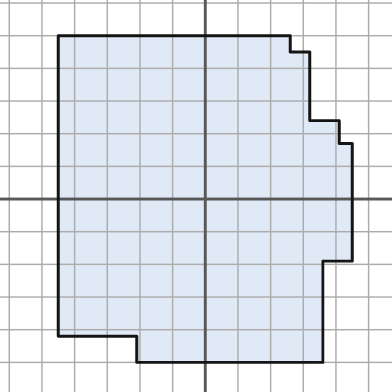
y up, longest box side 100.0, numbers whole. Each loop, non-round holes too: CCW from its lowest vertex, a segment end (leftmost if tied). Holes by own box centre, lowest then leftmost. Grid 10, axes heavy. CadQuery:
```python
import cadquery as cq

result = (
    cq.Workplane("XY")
    .moveTo(-21.0, -50.0)
    .lineTo(36.0, -50.0)
    .lineTo(36.0, -19.0)
    .lineTo(45.0, -19.0)
    .lineTo(45.0, 17.0)
    .lineTo(41.0, 17.0)
    .lineTo(41.0, 24.0)
    .lineTo(32.0, 24.0)
    .lineTo(32.0, 45.0)
    .lineTo(26.0, 45.0)
    .lineTo(26.0, 50.0)
    .lineTo(-45.0, 50.0)
    .lineTo(-45.0, -42.0)
    .lineTo(-21.0, -42.0)
    .close()
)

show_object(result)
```